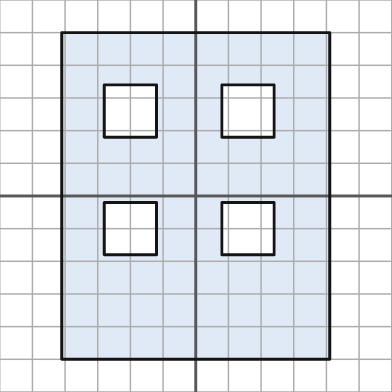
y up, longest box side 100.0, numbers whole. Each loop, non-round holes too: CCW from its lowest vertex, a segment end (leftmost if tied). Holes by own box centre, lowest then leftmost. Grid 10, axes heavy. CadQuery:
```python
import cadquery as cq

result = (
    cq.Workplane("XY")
    .moveTo(-41.0, -50.0)
    .lineTo(41.0, -50.0)
    .lineTo(41.0, 50.0)
    .lineTo(-41.0, 50.0)
    .close()
    .moveTo(-28.0, -18.0)
    .lineTo(-12.0, -18.0)
    .lineTo(-12.0, -2.0)
    .lineTo(-28.0, -2.0)
    .close()
    .moveTo(8.0, -18.0)
    .lineTo(24.0, -18.0)
    .lineTo(24.0, -2.0)
    .lineTo(8.0, -2.0)
    .close()
    .moveTo(-28.0, 18.0)
    .lineTo(-12.0, 18.0)
    .lineTo(-12.0, 34.0)
    .lineTo(-28.0, 34.0)
    .close()
    .moveTo(8.0, 18.0)
    .lineTo(24.0, 18.0)
    .lineTo(24.0, 34.0)
    .lineTo(8.0, 34.0)
    .close()
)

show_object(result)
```